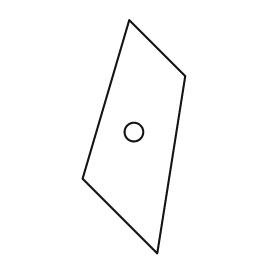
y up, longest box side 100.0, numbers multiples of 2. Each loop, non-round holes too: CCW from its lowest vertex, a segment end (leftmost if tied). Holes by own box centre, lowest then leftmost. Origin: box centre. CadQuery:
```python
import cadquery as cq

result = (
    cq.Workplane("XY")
    .moveTo(10.0, -50.0)
    .lineTo(22.0, 26.0)
    .lineTo(-2.0, 50.0)
    .lineTo(-22.0, -18.0)
    .close()
    .moveTo(0.0, 2.0)
    .circle(4.0)
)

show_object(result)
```